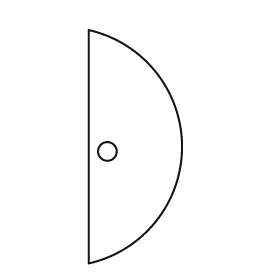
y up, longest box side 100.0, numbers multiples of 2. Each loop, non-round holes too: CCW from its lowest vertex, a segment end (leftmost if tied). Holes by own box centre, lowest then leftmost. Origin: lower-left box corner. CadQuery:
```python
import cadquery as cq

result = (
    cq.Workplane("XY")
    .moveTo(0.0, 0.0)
    .threePointArc((40.0, 50.0), (0.0, 100.0))
    .close()
    .moveTo(8.0, 48.0)
    .circle(4.0)
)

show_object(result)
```